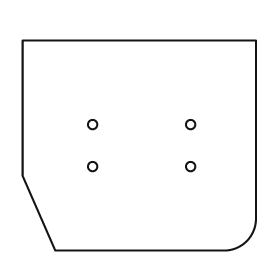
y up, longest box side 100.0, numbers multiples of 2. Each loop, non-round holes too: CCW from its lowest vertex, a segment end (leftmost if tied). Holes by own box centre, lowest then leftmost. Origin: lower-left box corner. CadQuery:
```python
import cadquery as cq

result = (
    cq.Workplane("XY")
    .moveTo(14.0, 0.0)
    .lineTo(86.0, 0.0)
    .threePointArc((96.0, 4.0), (100.0, 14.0))
    .lineTo(100.0, 90.0)
    .lineTo(0.0, 90.0)
    .lineTo(0.0, 32.0)
    .close()
    .moveTo(30.0, 36.0)
    .circle(2.0)
    .moveTo(72.0, 36.0)
    .circle(2.0)
    .moveTo(30.0, 54.0)
    .circle(2.0)
    .moveTo(72.0, 54.0)
    .circle(2.0)
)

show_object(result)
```